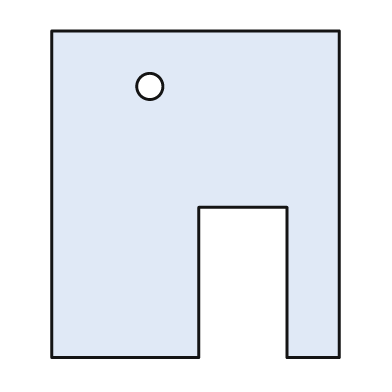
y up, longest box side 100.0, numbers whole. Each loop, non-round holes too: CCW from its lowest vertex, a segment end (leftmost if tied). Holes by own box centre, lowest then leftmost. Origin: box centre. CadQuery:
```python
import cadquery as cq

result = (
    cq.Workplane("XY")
    .moveTo(-44.0, -50.0)
    .lineTo(1.0, -50.0)
    .lineTo(1.0, -4.0)
    .lineTo(28.0, -4.0)
    .lineTo(28.0, -50.0)
    .lineTo(44.0, -50.0)
    .lineTo(44.0, 50.0)
    .lineTo(-44.0, 50.0)
    .close()
    .moveTo(-14.0, 33.0)
    .circle(4.0)
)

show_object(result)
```